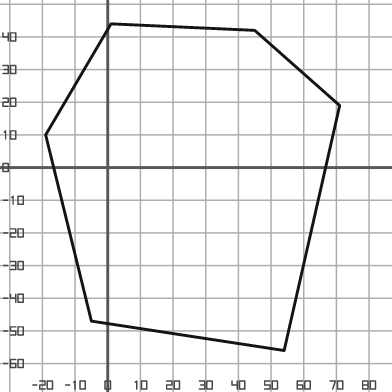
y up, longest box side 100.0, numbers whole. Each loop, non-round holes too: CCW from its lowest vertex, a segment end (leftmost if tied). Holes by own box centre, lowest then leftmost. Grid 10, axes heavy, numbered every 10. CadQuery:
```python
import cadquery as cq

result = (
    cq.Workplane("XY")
    .moveTo(54.0, -56.0)
    .lineTo(71.0, 19.0)
    .lineTo(45.0, 42.0)
    .lineTo(1.0, 44.0)
    .lineTo(-19.0, 10.0)
    .lineTo(-5.0, -47.0)
    .close()
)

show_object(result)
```